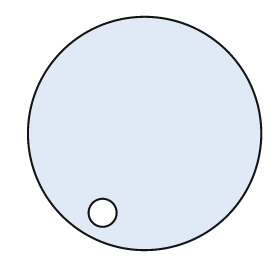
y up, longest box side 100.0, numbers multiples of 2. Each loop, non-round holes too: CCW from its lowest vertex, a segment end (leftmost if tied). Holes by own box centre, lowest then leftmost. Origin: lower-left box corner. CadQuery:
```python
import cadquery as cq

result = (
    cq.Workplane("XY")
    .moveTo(50.0, 50.0)
    .circle(50.0)
    .moveTo(32.0, 16.0)
    .circle(6.0)
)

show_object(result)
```